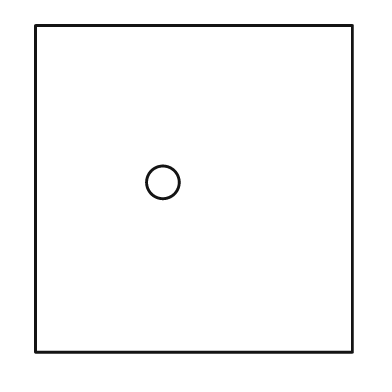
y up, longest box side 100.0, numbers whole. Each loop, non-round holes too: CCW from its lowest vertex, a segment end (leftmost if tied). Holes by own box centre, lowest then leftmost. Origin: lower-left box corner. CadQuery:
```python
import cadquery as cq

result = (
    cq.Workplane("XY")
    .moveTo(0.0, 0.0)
    .lineTo(97.0, 0.0)
    .lineTo(97.0, 100.0)
    .lineTo(0.0, 100.0)
    .close()
    .moveTo(39.0, 52.0)
    .circle(5.0)
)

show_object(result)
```